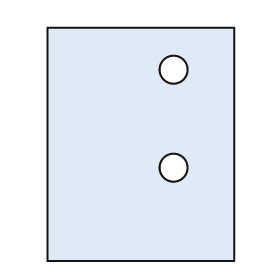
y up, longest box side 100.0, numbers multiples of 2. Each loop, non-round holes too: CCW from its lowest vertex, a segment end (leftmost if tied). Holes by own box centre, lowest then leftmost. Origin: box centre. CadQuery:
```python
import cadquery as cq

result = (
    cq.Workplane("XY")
    .moveTo(-40.0, -50.0)
    .lineTo(40.0, -50.0)
    .lineTo(40.0, 50.0)
    .lineTo(-40.0, 50.0)
    .close()
    .moveTo(14.0, -10.0)
    .circle(6.0)
    .moveTo(14.0, 32.0)
    .circle(6.0)
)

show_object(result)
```